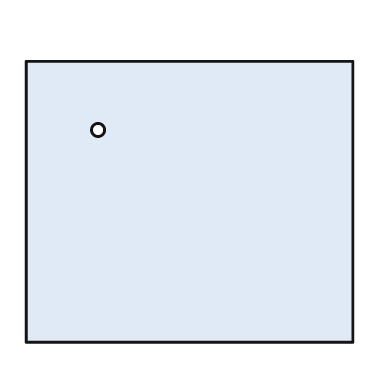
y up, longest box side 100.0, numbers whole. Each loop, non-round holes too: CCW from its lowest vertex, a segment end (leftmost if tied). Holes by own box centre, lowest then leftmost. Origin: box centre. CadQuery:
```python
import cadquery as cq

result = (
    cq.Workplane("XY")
    .moveTo(-50.0, -43.0)
    .lineTo(50.0, -43.0)
    .lineTo(50.0, 43.0)
    .lineTo(-50.0, 43.0)
    .close()
    .moveTo(-28.0, 22.0)
    .circle(2.0)
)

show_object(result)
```